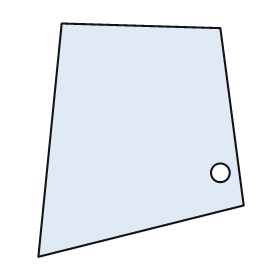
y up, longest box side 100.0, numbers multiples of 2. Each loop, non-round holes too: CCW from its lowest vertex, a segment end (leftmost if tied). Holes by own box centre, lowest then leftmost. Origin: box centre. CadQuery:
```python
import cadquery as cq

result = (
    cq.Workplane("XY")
    .moveTo(-44.0, -50.0)
    .lineTo(44.0, -28.0)
    .lineTo(34.0, 48.0)
    .lineTo(-34.0, 50.0)
    .close()
    .moveTo(34.0, -14.0)
    .circle(4.0)
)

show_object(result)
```